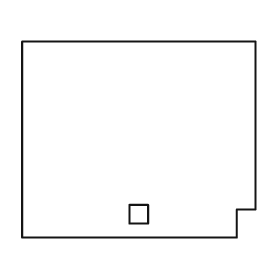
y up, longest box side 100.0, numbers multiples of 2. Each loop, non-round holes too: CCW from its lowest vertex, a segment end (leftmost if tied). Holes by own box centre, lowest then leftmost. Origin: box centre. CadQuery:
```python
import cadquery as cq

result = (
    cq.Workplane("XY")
    .moveTo(-50.0, -42.0)
    .lineTo(42.0, -42.0)
    .lineTo(42.0, -30.0)
    .lineTo(50.0, -30.0)
    .lineTo(50.0, 42.0)
    .lineTo(-50.0, 42.0)
    .close()
    .moveTo(-4.0, -36.0)
    .lineTo(4.0, -36.0)
    .lineTo(4.0, -28.0)
    .lineTo(-4.0, -28.0)
    .close()
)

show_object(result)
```